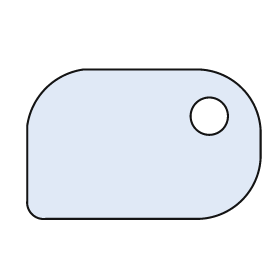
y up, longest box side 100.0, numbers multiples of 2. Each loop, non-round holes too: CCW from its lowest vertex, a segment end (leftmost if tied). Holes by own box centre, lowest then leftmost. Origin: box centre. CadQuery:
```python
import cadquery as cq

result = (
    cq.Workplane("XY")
    .moveTo(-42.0, -32.0)
    .lineTo(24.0, -32.0)
    .threePointArc((42.0, -24.0), (50.0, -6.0))
    .lineTo(50.0, 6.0)
    .threePointArc((42.0, 24.0), (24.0, 32.0))
    .lineTo(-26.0, 32.0)
    .threePointArc((-42.0, 24.0), (-50.0, 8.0))
    .lineTo(-50.0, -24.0)
    .threePointArc((-48.0, -30.0), (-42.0, -32.0))
    .close()
    .moveTo(28.0, 12.0)
    .circle(8.0)
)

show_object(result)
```